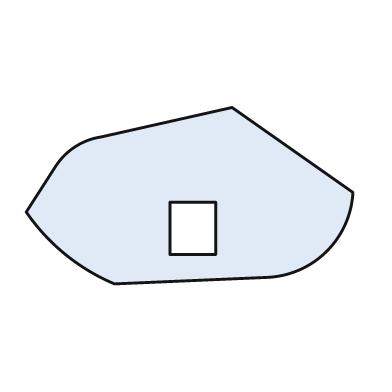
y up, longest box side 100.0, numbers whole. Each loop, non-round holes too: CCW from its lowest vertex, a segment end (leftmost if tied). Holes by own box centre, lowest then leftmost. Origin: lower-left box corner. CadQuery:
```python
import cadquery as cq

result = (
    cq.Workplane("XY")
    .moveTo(27.0, 0.0)
    .lineTo(74.0, 2.0)
    .threePointArc((92.0, 10.0), (100.0, 28.0))
    .lineTo(63.0, 54.0)
    .lineTo(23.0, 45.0)
    .threePointArc((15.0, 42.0), (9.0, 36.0))
    .lineTo(0.0, 22.0)
    .threePointArc((12.0, 9.0), (27.0, 0.0))
    .close()
    .moveTo(44.0, 9.0)
    .lineTo(58.0, 9.0)
    .lineTo(58.0, 25.0)
    .lineTo(44.0, 25.0)
    .close()
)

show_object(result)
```